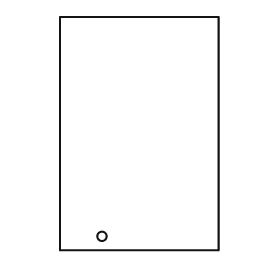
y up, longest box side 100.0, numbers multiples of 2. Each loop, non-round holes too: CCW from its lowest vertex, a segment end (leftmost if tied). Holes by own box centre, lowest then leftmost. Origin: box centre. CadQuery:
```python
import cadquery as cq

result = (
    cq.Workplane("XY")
    .moveTo(-34.0, -50.0)
    .lineTo(34.0, -50.0)
    .lineTo(34.0, 50.0)
    .lineTo(-34.0, 50.0)
    .close()
    .moveTo(-16.0, -44.0)
    .circle(2.0)
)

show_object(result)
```